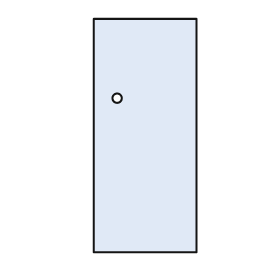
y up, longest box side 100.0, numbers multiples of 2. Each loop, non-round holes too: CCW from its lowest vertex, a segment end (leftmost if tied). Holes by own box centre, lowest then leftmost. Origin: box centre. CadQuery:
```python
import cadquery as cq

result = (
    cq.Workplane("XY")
    .moveTo(-22.0, -50.0)
    .lineTo(22.0, -50.0)
    .lineTo(22.0, 50.0)
    .lineTo(-22.0, 50.0)
    .close()
    .moveTo(-12.0, 16.0)
    .circle(2.0)
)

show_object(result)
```